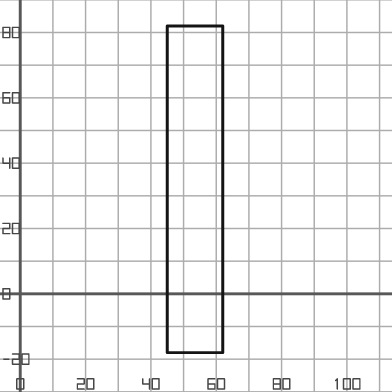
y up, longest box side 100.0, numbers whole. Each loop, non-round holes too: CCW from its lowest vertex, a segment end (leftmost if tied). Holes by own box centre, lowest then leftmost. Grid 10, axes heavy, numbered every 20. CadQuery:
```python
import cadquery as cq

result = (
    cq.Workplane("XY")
    .moveTo(45.0, -18.0)
    .lineTo(62.0, -18.0)
    .lineTo(62.0, 82.0)
    .lineTo(45.0, 82.0)
    .close()
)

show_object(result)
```